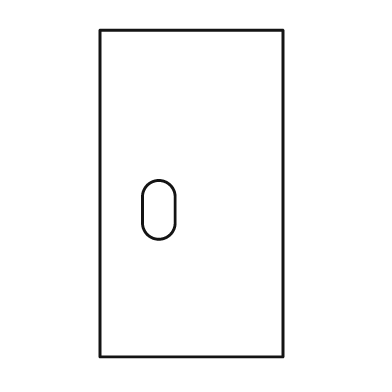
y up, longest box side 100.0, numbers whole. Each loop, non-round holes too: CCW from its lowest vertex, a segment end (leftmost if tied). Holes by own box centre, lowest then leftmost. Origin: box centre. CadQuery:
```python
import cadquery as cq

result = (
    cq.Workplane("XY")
    .moveTo(-28.0, -50.0)
    .lineTo(28.0, -50.0)
    .lineTo(28.0, 50.0)
    .lineTo(-28.0, 50.0)
    .close()
    .moveTo(-15.0, -9.0)
    .threePointArc((-10.0, -14.0), (-5.0, -9.0))
    .lineTo(-5.0, -1.0)
    .threePointArc((-10.0, 4.0), (-15.0, -1.0))
    .close()
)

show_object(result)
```